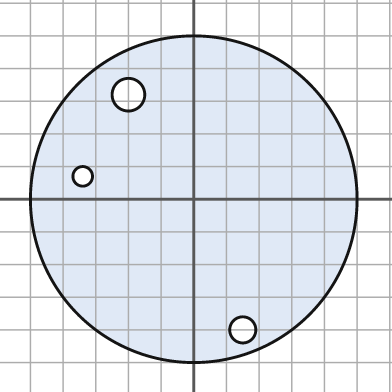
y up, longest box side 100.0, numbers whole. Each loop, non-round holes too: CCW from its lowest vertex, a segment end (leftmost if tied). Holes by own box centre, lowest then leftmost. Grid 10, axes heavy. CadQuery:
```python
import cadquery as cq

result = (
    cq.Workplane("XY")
    .moveTo(0.0, 0.0)
    .circle(50.0)
    .moveTo(15.0, -40.0)
    .circle(4.0)
    .moveTo(-34.0, 7.0)
    .circle(3.0)
    .moveTo(-20.0, 32.0)
    .circle(5.0)
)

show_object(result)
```